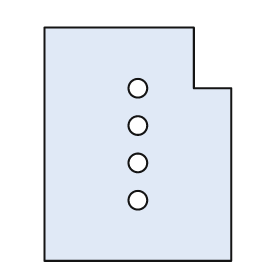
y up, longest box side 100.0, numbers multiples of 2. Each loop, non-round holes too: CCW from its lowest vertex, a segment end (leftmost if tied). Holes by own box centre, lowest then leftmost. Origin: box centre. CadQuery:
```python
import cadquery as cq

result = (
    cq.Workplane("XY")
    .moveTo(-40.0, -50.0)
    .lineTo(40.0, -50.0)
    .lineTo(40.0, 24.0)
    .lineTo(24.0, 24.0)
    .lineTo(24.0, 50.0)
    .lineTo(-40.0, 50.0)
    .close()
    .moveTo(0.0, -24.0)
    .circle(4.0)
    .moveTo(0.0, -8.0)
    .circle(4.0)
    .moveTo(0.0, 8.0)
    .circle(4.0)
    .moveTo(0.0, 24.0)
    .circle(4.0)
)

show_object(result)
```